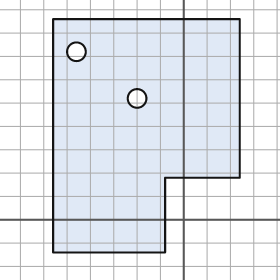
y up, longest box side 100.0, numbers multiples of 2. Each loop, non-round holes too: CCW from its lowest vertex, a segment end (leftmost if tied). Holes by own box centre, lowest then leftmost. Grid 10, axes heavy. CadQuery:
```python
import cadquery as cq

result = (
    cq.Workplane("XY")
    .moveTo(-56.0, -14.0)
    .lineTo(-8.0, -14.0)
    .lineTo(-8.0, 18.0)
    .lineTo(24.0, 18.0)
    .lineTo(24.0, 86.0)
    .lineTo(-56.0, 86.0)
    .close()
    .moveTo(-20.0, 52.0)
    .circle(4.0)
    .moveTo(-46.0, 72.0)
    .circle(4.0)
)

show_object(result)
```